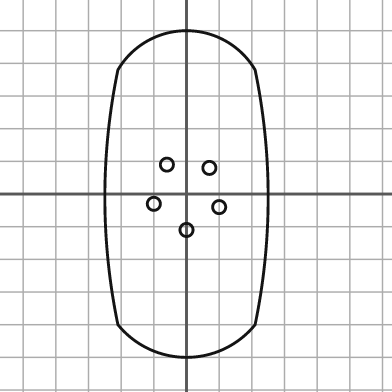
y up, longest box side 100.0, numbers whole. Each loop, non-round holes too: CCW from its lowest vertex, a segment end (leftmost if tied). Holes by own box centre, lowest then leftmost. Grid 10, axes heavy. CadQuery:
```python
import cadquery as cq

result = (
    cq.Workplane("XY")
    .moveTo(-21.0, -40.0)
    .threePointArc((0.0, -50.0), (21.0, -40.0))
    .threePointArc((25.0, -1.0), (21.0, 38.0))
    .threePointArc((0.0, 50.0), (-21.0, 38.0))
    .threePointArc((-25.0, -1.0), (-21.0, -40.0))
    .close()
    .moveTo(0.0, -11.0)
    .circle(2.0)
    .moveTo(10.0, -4.0)
    .circle(2.0)
    .moveTo(-10.0, -3.0)
    .circle(2.0)
    .moveTo(7.0, 8.0)
    .circle(2.0)
    .moveTo(-6.0, 9.0)
    .circle(2.0)
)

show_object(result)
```